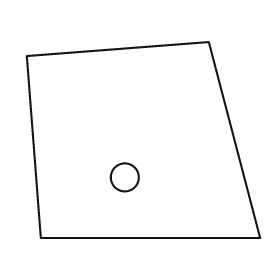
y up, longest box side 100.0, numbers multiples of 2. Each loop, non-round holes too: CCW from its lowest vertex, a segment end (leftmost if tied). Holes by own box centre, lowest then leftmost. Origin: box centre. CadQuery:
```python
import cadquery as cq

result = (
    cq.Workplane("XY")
    .moveTo(-44.0, -42.0)
    .lineTo(50.0, -42.0)
    .lineTo(28.0, 42.0)
    .lineTo(-50.0, 36.0)
    .close()
    .moveTo(-8.0, -16.0)
    .circle(6.0)
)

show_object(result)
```